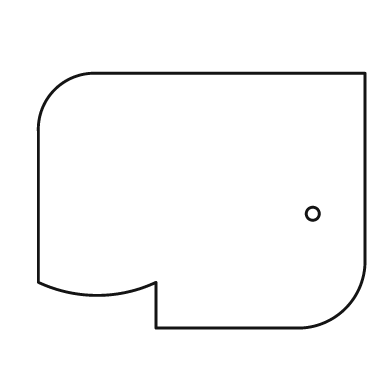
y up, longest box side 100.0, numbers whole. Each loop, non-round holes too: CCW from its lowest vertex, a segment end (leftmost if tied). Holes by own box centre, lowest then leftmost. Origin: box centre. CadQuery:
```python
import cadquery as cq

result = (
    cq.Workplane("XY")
    .moveTo(-14.0, -39.0)
    .lineTo(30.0, -39.0)
    .threePointArc((44.0, -33.0), (50.0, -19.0))
    .lineTo(50.0, 39.0)
    .lineTo(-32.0, 39.0)
    .threePointArc((-45.0, 34.0), (-50.0, 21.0))
    .lineTo(-50.0, -25.0)
    .threePointArc((-32.0, -29.0), (-14.0, -25.0))
    .close()
    .moveTo(34.0, -4.0)
    .circle(2.0)
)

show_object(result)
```